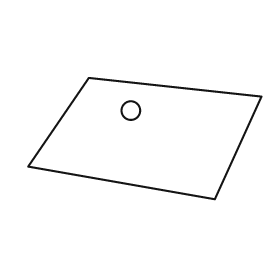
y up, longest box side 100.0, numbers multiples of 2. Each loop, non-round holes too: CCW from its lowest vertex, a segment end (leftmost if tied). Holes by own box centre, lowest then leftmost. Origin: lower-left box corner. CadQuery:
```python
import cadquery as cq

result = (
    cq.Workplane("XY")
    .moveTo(80.0, 0.0)
    .lineTo(100.0, 44.0)
    .lineTo(26.0, 52.0)
    .lineTo(0.0, 14.0)
    .close()
    .moveTo(44.0, 38.0)
    .circle(4.0)
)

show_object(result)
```